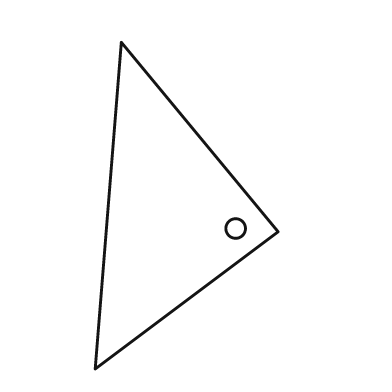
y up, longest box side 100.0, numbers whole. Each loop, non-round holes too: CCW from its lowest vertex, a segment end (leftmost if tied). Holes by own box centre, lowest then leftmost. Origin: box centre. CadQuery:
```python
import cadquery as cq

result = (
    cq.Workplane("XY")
    .moveTo(-28.0, -50.0)
    .lineTo(28.0, -8.0)
    .lineTo(-20.0, 50.0)
    .close()
    .moveTo(15.0, -7.0)
    .circle(3.0)
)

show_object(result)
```